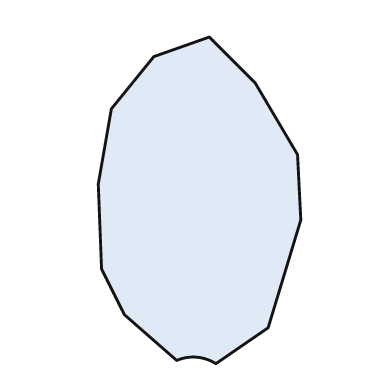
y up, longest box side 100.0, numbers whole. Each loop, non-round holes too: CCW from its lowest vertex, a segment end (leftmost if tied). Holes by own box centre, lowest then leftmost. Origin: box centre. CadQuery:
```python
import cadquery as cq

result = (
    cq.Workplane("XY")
    .moveTo(5.0, -50.0)
    .lineTo(21.0, -39.0)
    .lineTo(31.0, -6.0)
    .lineTo(30.0, 14.0)
    .lineTo(17.0, 36.0)
    .lineTo(3.0, 50.0)
    .lineTo(-14.0, 44.0)
    .lineTo(-27.0, 28.0)
    .lineTo(-31.0, 5.0)
    .lineTo(-30.0, -21.0)
    .lineTo(-23.0, -35.0)
    .lineTo(-7.0, -49.0)
    .threePointArc((-1.0, -48.0), (5.0, -50.0))
    .close()
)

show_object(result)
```